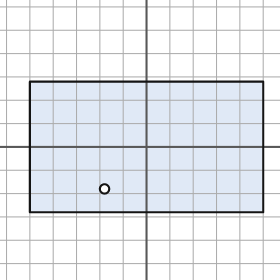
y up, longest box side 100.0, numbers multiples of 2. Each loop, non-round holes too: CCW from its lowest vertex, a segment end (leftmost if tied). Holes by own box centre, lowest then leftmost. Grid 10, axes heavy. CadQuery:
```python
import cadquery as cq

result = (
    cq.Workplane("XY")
    .moveTo(-50.0, -28.0)
    .lineTo(50.0, -28.0)
    .lineTo(50.0, 28.0)
    .lineTo(-50.0, 28.0)
    .close()
    .moveTo(-18.0, -18.0)
    .circle(2.0)
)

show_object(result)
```